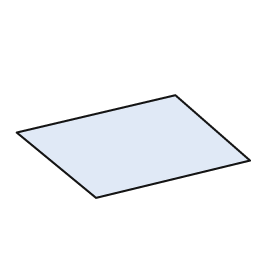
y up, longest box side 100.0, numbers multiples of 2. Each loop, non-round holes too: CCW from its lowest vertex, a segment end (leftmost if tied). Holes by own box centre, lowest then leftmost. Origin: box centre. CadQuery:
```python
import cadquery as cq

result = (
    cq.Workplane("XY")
    .moveTo(-16.0, -22.0)
    .lineTo(50.0, -6.0)
    .lineTo(18.0, 22.0)
    .lineTo(-50.0, 6.0)
    .close()
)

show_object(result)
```